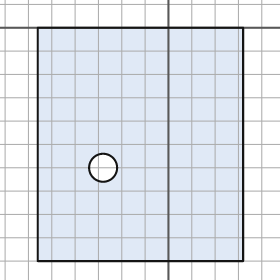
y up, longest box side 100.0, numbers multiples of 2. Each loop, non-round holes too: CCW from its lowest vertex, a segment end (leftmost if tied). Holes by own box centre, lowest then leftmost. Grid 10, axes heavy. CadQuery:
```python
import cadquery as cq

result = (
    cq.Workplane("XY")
    .moveTo(-56.0, -100.0)
    .lineTo(32.0, -100.0)
    .lineTo(32.0, 0.0)
    .lineTo(-56.0, 0.0)
    .close()
    .moveTo(-28.0, -60.0)
    .circle(6.0)
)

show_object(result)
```